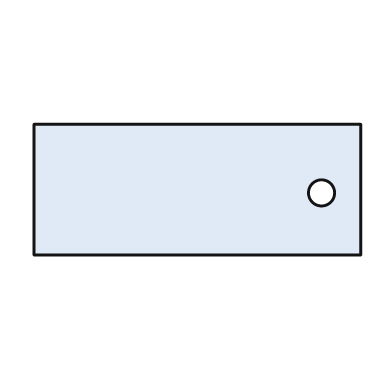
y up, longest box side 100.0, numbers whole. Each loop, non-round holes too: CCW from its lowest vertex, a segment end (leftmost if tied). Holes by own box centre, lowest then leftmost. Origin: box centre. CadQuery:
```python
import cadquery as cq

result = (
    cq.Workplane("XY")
    .moveTo(-50.0, -20.0)
    .lineTo(50.0, -20.0)
    .lineTo(50.0, 20.0)
    .lineTo(-50.0, 20.0)
    .close()
    .moveTo(38.0, -1.0)
    .circle(4.0)
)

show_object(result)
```